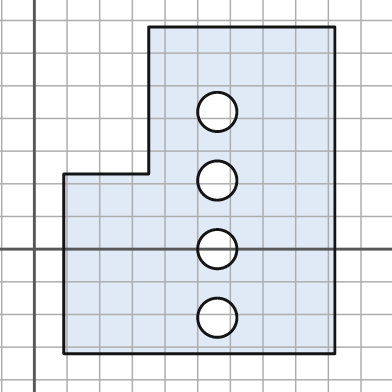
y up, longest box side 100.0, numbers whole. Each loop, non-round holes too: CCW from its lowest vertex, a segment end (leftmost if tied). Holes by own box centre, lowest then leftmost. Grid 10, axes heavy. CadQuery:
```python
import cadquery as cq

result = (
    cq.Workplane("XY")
    .moveTo(9.0, -32.0)
    .lineTo(92.0, -32.0)
    .lineTo(92.0, 68.0)
    .lineTo(35.0, 68.0)
    .lineTo(35.0, 23.0)
    .lineTo(9.0, 23.0)
    .close()
    .moveTo(56.0, -21.0)
    .circle(6.0)
    .moveTo(56.0, 0.0)
    .circle(6.0)
    .moveTo(56.0, 21.0)
    .circle(6.0)
    .moveTo(56.0, 42.0)
    .circle(6.0)
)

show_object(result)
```